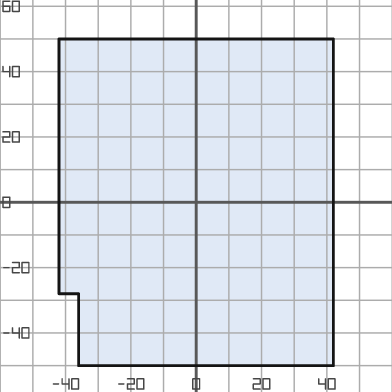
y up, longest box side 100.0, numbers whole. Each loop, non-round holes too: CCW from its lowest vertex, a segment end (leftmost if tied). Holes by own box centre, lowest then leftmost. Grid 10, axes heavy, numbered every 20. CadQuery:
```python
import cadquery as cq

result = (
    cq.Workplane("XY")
    .moveTo(-36.0, -50.0)
    .lineTo(42.0, -50.0)
    .lineTo(42.0, 50.0)
    .lineTo(-42.0, 50.0)
    .lineTo(-42.0, -28.0)
    .lineTo(-36.0, -28.0)
    .close()
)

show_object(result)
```